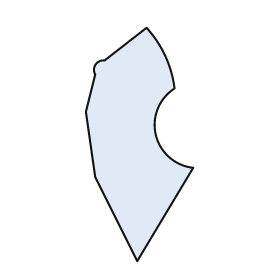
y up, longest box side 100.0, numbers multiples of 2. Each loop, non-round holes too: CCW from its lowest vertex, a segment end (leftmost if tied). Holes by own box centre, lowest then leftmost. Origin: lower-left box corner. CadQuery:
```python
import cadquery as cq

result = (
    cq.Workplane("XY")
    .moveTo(22.0, 0.0)
    .lineTo(46.0, 40.0)
    .threePointArc((30.0, 54.0), (38.0, 74.0))
    .threePointArc((34.0, 88.0), (26.0, 100.0))
    .lineTo(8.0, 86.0)
    .threePointArc((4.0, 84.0), (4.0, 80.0))
    .lineTo(0.0, 64.0)
    .lineTo(4.0, 36.0)
    .close()
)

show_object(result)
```